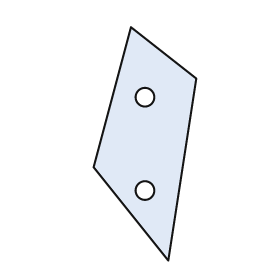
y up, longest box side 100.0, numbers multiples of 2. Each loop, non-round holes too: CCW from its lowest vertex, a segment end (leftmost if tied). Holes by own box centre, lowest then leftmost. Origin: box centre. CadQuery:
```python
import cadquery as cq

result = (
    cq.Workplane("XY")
    .moveTo(10.0, -50.0)
    .lineTo(22.0, 28.0)
    .lineTo(-6.0, 50.0)
    .lineTo(-22.0, -10.0)
    .close()
    .moveTo(0.0, -20.0)
    .circle(4.0)
    .moveTo(0.0, 20.0)
    .circle(4.0)
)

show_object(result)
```